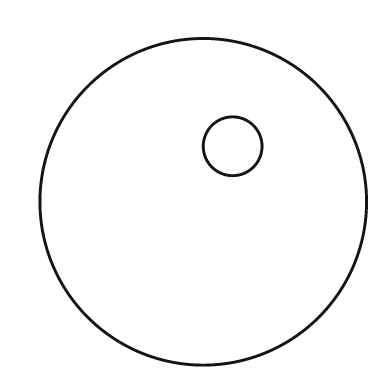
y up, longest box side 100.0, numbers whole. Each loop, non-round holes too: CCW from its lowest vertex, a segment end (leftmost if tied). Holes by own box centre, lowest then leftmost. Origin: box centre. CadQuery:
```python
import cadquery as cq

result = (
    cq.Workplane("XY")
    .moveTo(0.0, 0.0)
    .circle(50.0)
    .moveTo(9.0, 17.0)
    .circle(9.0)
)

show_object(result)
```